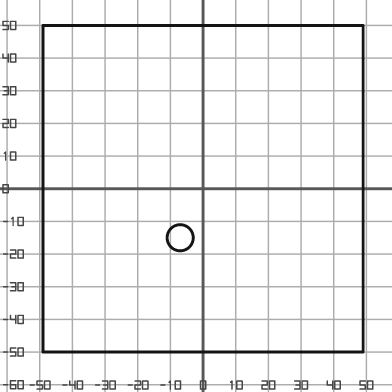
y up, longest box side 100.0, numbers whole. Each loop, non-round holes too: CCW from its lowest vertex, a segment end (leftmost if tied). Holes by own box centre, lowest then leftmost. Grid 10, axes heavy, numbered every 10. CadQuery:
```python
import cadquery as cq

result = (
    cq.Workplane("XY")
    .moveTo(-49.0, -50.0)
    .lineTo(49.0, -50.0)
    .lineTo(49.0, 50.0)
    .lineTo(-49.0, 50.0)
    .close()
    .moveTo(-7.0, -15.0)
    .circle(4.0)
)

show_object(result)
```